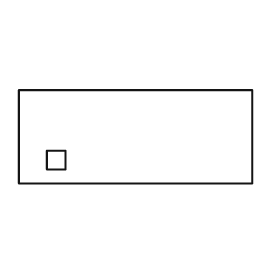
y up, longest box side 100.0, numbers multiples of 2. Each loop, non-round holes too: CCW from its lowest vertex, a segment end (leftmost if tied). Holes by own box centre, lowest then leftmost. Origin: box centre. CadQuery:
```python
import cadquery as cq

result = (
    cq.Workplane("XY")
    .moveTo(-50.0, -20.0)
    .lineTo(50.0, -20.0)
    .lineTo(50.0, 20.0)
    .lineTo(-50.0, 20.0)
    .close()
    .moveTo(-38.0, -14.0)
    .lineTo(-30.0, -14.0)
    .lineTo(-30.0, -6.0)
    .lineTo(-38.0, -6.0)
    .close()
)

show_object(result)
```